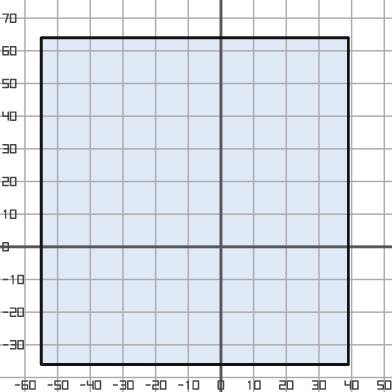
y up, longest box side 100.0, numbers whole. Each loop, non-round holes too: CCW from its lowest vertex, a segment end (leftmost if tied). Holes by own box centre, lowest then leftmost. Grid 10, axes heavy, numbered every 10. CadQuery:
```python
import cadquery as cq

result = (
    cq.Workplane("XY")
    .moveTo(-55.0, -36.0)
    .lineTo(39.0, -36.0)
    .lineTo(39.0, 64.0)
    .lineTo(-55.0, 64.0)
    .close()
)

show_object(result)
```